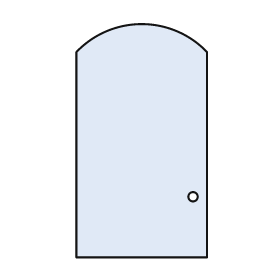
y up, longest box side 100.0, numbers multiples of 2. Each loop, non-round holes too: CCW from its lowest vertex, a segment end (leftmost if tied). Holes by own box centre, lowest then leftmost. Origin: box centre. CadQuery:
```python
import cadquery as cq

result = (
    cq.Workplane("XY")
    .moveTo(-28.0, -50.0)
    .lineTo(28.0, -50.0)
    .lineTo(28.0, 38.0)
    .threePointArc((0.0, 50.0), (-28.0, 38.0))
    .close()
    .moveTo(22.0, -24.0)
    .circle(2.0)
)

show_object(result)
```